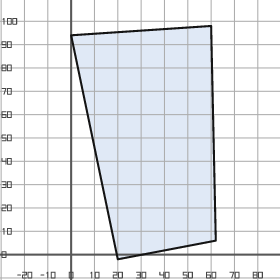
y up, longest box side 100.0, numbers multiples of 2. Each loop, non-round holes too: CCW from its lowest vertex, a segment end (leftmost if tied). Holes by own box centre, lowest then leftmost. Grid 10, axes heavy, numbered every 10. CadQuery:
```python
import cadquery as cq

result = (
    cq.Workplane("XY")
    .moveTo(20.0, -2.0)
    .lineTo(62.0, 6.0)
    .lineTo(60.0, 98.0)
    .lineTo(0.0, 94.0)
    .close()
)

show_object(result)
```